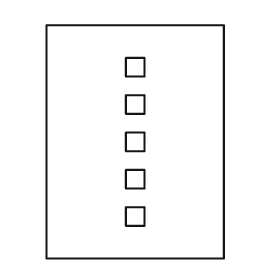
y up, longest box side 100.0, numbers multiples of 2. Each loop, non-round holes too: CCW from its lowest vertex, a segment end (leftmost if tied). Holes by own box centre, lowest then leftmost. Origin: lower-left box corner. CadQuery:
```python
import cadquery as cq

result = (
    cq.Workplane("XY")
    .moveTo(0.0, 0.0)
    .lineTo(76.0, 0.0)
    .lineTo(76.0, 100.0)
    .lineTo(0.0, 100.0)
    .close()
    .moveTo(34.0, 14.0)
    .lineTo(42.0, 14.0)
    .lineTo(42.0, 22.0)
    .lineTo(34.0, 22.0)
    .close()
    .moveTo(34.0, 30.0)
    .lineTo(42.0, 30.0)
    .lineTo(42.0, 38.0)
    .lineTo(34.0, 38.0)
    .close()
    .moveTo(34.0, 46.0)
    .lineTo(42.0, 46.0)
    .lineTo(42.0, 54.0)
    .lineTo(34.0, 54.0)
    .close()
    .moveTo(34.0, 62.0)
    .lineTo(42.0, 62.0)
    .lineTo(42.0, 70.0)
    .lineTo(34.0, 70.0)
    .close()
    .moveTo(34.0, 78.0)
    .lineTo(42.0, 78.0)
    .lineTo(42.0, 86.0)
    .lineTo(34.0, 86.0)
    .close()
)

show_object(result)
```